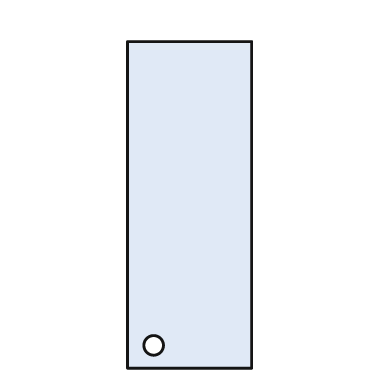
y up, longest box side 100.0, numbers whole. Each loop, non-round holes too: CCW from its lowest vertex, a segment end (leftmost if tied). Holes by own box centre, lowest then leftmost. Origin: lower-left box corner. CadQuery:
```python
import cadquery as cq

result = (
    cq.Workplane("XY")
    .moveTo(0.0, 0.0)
    .lineTo(38.0, 0.0)
    .lineTo(38.0, 100.0)
    .lineTo(0.0, 100.0)
    .close()
    .moveTo(8.0, 7.0)
    .circle(3.0)
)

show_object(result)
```